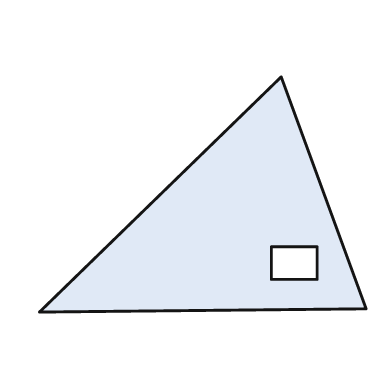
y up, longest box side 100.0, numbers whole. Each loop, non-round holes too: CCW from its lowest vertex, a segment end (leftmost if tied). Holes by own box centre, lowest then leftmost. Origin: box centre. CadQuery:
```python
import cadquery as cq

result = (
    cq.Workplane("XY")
    .moveTo(-50.0, -36.0)
    .lineTo(50.0, -35.0)
    .lineTo(24.0, 36.0)
    .close()
    .moveTo(21.0, -26.0)
    .lineTo(35.0, -26.0)
    .lineTo(35.0, -16.0)
    .lineTo(21.0, -16.0)
    .close()
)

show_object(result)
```